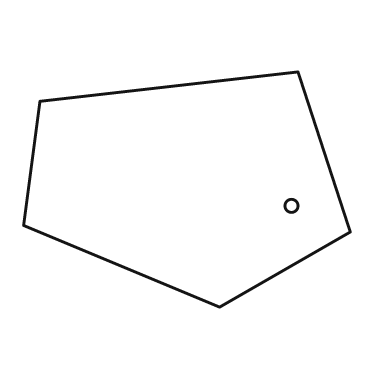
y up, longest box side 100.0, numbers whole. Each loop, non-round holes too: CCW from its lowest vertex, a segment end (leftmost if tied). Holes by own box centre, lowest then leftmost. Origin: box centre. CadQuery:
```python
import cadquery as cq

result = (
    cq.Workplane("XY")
    .moveTo(10.0, -36.0)
    .lineTo(50.0, -13.0)
    .lineTo(34.0, 36.0)
    .lineTo(-45.0, 27.0)
    .lineTo(-50.0, -11.0)
    .close()
    .moveTo(32.0, -5.0)
    .circle(2.0)
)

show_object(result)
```